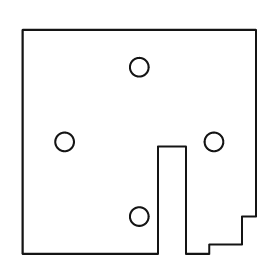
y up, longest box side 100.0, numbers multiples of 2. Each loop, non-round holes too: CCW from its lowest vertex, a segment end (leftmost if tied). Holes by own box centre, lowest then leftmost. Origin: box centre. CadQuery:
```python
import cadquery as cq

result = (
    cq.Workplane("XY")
    .moveTo(-50.0, -48.0)
    .lineTo(8.0, -48.0)
    .lineTo(8.0, -2.0)
    .lineTo(20.0, -2.0)
    .lineTo(20.0, -48.0)
    .lineTo(30.0, -48.0)
    .lineTo(30.0, -44.0)
    .lineTo(44.0, -44.0)
    .lineTo(44.0, -32.0)
    .lineTo(50.0, -32.0)
    .lineTo(50.0, 48.0)
    .lineTo(-50.0, 48.0)
    .close()
    .moveTo(0.0, -32.0)
    .circle(4.0)
    .moveTo(-32.0, 0.0)
    .circle(4.0)
    .moveTo(32.0, 0.0)
    .circle(4.0)
    .moveTo(0.0, 32.0)
    .circle(4.0)
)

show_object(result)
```